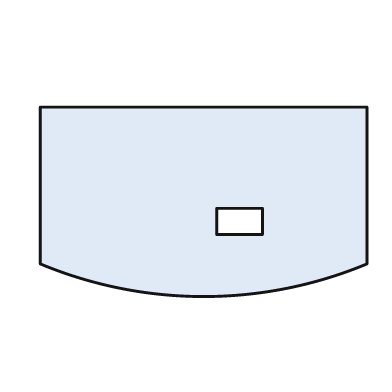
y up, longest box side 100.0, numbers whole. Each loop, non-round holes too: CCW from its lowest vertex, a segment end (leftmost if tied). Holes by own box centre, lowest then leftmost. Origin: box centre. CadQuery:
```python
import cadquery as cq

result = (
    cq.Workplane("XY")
    .moveTo(-50.0, -19.0)
    .threePointArc((0.0, -29.0), (50.0, -19.0))
    .lineTo(50.0, 29.0)
    .lineTo(-50.0, 29.0)
    .close()
    .moveTo(4.0, -10.0)
    .lineTo(18.0, -10.0)
    .lineTo(18.0, -2.0)
    .lineTo(4.0, -2.0)
    .close()
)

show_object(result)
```